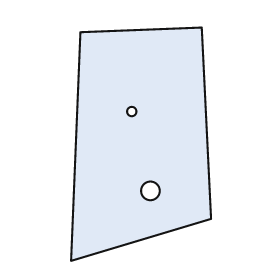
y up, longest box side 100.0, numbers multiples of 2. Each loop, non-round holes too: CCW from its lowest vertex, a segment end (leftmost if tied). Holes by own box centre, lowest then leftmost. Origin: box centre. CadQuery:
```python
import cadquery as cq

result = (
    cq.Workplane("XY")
    .moveTo(-30.0, -50.0)
    .lineTo(30.0, -32.0)
    .lineTo(26.0, 50.0)
    .lineTo(-26.0, 48.0)
    .close()
    .moveTo(4.0, -20.0)
    .circle(4.0)
    .moveTo(-4.0, 14.0)
    .circle(2.0)
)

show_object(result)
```